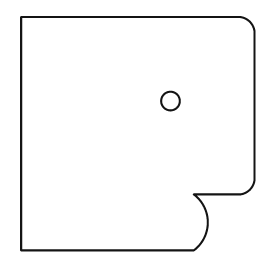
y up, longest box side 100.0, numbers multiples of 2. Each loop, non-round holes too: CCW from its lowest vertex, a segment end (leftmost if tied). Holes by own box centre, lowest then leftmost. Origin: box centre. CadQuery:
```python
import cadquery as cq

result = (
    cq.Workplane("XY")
    .moveTo(-50.0, -50.0)
    .lineTo(24.0, -50.0)
    .threePointArc((30.0, -38.0), (24.0, -26.0))
    .lineTo(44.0, -26.0)
    .threePointArc((48.0, -24.0), (50.0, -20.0))
    .lineTo(50.0, 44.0)
    .threePointArc((48.0, 48.0), (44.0, 50.0))
    .lineTo(-50.0, 50.0)
    .close()
    .moveTo(14.0, 14.0)
    .circle(4.0)
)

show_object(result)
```